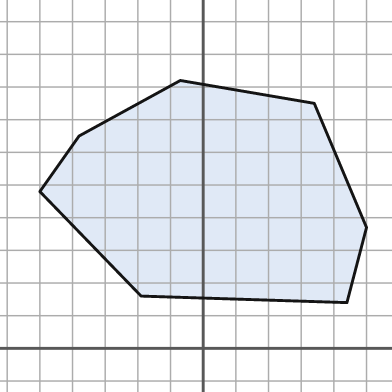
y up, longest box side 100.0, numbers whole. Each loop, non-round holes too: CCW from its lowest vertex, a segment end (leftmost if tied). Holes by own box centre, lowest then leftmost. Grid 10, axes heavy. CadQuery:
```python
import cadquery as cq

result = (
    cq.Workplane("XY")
    .moveTo(44.0, 14.0)
    .lineTo(50.0, 37.0)
    .lineTo(34.0, 75.0)
    .lineTo(-7.0, 82.0)
    .lineTo(-38.0, 65.0)
    .lineTo(-50.0, 48.0)
    .lineTo(-19.0, 16.0)
    .close()
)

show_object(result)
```